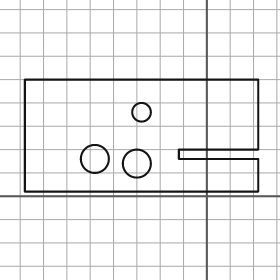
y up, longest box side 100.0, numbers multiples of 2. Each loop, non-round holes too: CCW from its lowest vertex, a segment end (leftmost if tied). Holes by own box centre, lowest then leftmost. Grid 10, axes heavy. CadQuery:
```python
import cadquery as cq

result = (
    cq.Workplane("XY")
    .moveTo(-78.0, 2.0)
    .lineTo(22.0, 2.0)
    .lineTo(22.0, 16.0)
    .lineTo(-12.0, 16.0)
    .lineTo(-12.0, 20.0)
    .lineTo(22.0, 20.0)
    .lineTo(22.0, 50.0)
    .lineTo(-78.0, 50.0)
    .close()
    .moveTo(-30.0, 14.0)
    .circle(6.0)
    .moveTo(-48.0, 16.0)
    .circle(6.0)
    .moveTo(-28.0, 36.0)
    .circle(4.0)
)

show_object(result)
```